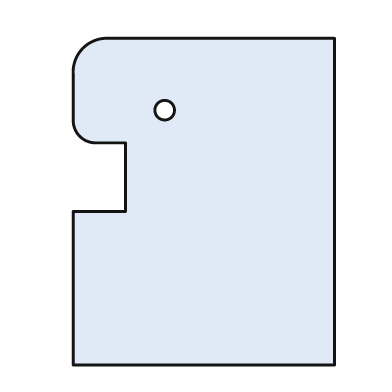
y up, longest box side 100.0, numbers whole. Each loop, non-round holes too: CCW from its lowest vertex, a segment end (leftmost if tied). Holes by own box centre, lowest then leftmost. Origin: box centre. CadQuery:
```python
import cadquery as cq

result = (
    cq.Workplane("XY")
    .moveTo(-40.0, -50.0)
    .lineTo(40.0, -50.0)
    .lineTo(40.0, 50.0)
    .lineTo(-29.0, 50.0)
    .threePointArc((-37.0, 47.0), (-40.0, 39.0))
    .lineTo(-40.0, 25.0)
    .threePointArc((-38.0, 20.0), (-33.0, 18.0))
    .lineTo(-24.0, 18.0)
    .lineTo(-24.0, -3.0)
    .lineTo(-40.0, -3.0)
    .close()
    .moveTo(-12.0, 28.0)
    .circle(3.0)
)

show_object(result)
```